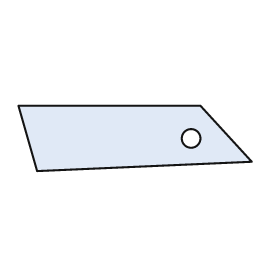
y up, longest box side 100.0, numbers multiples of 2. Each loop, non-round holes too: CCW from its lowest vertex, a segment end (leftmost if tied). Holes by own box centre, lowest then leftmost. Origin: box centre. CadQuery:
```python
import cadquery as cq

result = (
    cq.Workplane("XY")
    .moveTo(-42.0, -14.0)
    .lineTo(50.0, -10.0)
    .lineTo(28.0, 14.0)
    .lineTo(-50.0, 14.0)
    .close()
    .moveTo(24.0, 0.0)
    .circle(4.0)
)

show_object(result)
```